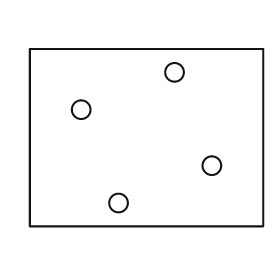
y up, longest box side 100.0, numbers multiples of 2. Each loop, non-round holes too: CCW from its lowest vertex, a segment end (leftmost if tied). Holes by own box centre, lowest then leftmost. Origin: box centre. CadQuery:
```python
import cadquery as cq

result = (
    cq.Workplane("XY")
    .moveTo(-50.0, -38.0)
    .lineTo(50.0, -38.0)
    .lineTo(50.0, 38.0)
    .lineTo(-50.0, 38.0)
    .close()
    .moveTo(-12.0, -28.0)
    .circle(4.0)
    .moveTo(28.0, -12.0)
    .circle(4.0)
    .moveTo(-28.0, 12.0)
    .circle(4.0)
    .moveTo(12.0, 28.0)
    .circle(4.0)
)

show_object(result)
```